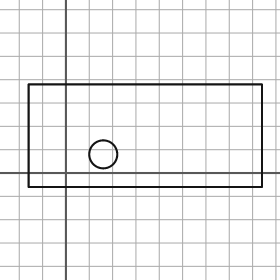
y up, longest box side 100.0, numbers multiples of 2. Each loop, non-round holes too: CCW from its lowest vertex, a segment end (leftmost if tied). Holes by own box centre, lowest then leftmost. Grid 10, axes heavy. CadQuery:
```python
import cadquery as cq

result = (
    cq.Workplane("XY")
    .moveTo(-16.0, -6.0)
    .lineTo(84.0, -6.0)
    .lineTo(84.0, 38.0)
    .lineTo(-16.0, 38.0)
    .close()
    .moveTo(16.0, 8.0)
    .circle(6.0)
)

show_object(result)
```